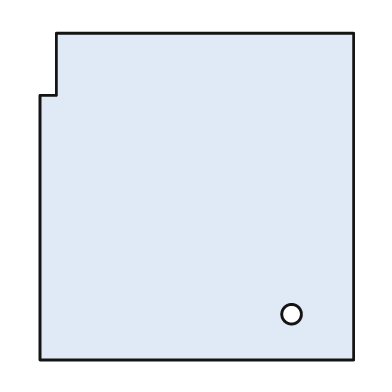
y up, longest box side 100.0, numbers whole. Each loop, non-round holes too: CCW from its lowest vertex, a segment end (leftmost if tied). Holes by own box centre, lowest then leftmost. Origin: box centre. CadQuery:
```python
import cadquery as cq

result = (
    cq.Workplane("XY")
    .moveTo(-48.0, -50.0)
    .lineTo(48.0, -50.0)
    .lineTo(48.0, 50.0)
    .lineTo(-43.0, 50.0)
    .lineTo(-43.0, 31.0)
    .lineTo(-48.0, 31.0)
    .close()
    .moveTo(29.0, -36.0)
    .circle(3.0)
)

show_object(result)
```